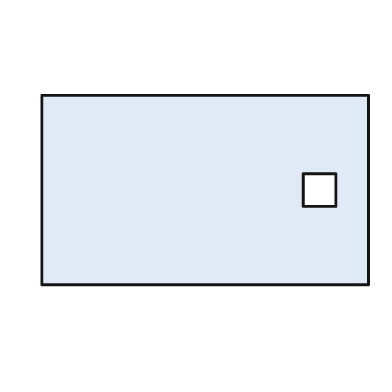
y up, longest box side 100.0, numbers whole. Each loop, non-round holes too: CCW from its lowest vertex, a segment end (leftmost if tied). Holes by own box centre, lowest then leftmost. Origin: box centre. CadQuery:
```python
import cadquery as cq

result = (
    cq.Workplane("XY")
    .moveTo(-50.0, -29.0)
    .lineTo(50.0, -29.0)
    .lineTo(50.0, 29.0)
    .lineTo(-50.0, 29.0)
    .close()
    .moveTo(30.0, -5.0)
    .lineTo(40.0, -5.0)
    .lineTo(40.0, 5.0)
    .lineTo(30.0, 5.0)
    .close()
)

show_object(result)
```